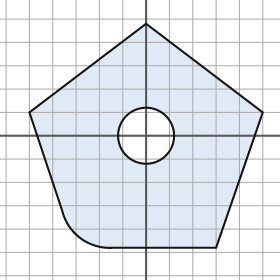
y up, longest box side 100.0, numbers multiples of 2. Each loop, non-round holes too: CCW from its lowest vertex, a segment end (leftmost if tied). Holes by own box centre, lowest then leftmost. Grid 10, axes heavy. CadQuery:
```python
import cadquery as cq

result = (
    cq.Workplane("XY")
    .moveTo(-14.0, -48.0)
    .lineTo(30.0, -48.0)
    .lineTo(50.0, 10.0)
    .lineTo(0.0, 48.0)
    .lineTo(-50.0, 10.0)
    .lineTo(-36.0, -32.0)
    .threePointArc((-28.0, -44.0), (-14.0, -48.0))
    .close()
    .moveTo(0.0, 0.0)
    .circle(12.0)
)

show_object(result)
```